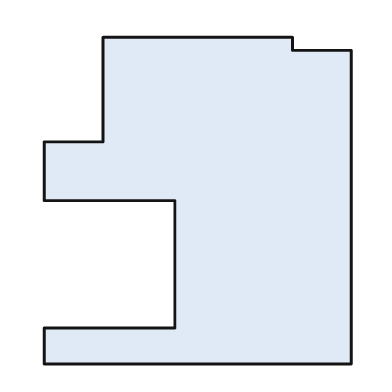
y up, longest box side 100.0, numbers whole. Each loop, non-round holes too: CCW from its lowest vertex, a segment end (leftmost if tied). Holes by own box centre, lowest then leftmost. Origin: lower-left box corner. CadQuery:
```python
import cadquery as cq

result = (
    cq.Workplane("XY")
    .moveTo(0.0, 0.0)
    .lineTo(94.0, 0.0)
    .lineTo(94.0, 96.0)
    .lineTo(76.0, 96.0)
    .lineTo(76.0, 100.0)
    .lineTo(18.0, 100.0)
    .lineTo(18.0, 68.0)
    .lineTo(0.0, 68.0)
    .lineTo(0.0, 50.0)
    .lineTo(40.0, 50.0)
    .lineTo(40.0, 11.0)
    .lineTo(0.0, 11.0)
    .close()
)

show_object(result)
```